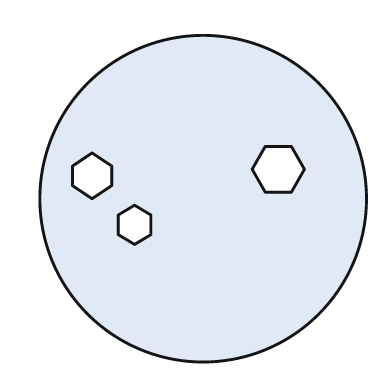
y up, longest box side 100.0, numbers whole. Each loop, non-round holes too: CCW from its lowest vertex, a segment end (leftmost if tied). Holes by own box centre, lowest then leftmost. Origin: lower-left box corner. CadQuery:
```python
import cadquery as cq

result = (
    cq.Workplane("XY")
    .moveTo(50.0, 50.0)
    .circle(50.0)
    .moveTo(29.0, 36.0)
    .lineTo(34.0, 39.0)
    .lineTo(34.0, 45.0)
    .lineTo(29.0, 48.0)
    .lineTo(24.0, 45.0)
    .lineTo(24.0, 39.0)
    .close()
    .moveTo(16.0, 50.0)
    .lineTo(22.0, 54.0)
    .lineTo(22.0, 60.0)
    .lineTo(16.0, 64.0)
    .lineTo(10.0, 60.0)
    .lineTo(10.0, 54.0)
    .close()
    .moveTo(69.0, 52.0)
    .lineTo(77.0, 52.0)
    .lineTo(81.0, 59.0)
    .lineTo(77.0, 66.0)
    .lineTo(69.0, 66.0)
    .lineTo(65.0, 59.0)
    .close()
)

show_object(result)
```